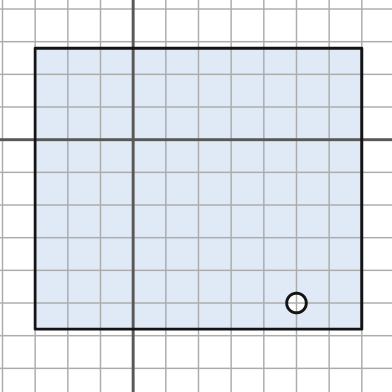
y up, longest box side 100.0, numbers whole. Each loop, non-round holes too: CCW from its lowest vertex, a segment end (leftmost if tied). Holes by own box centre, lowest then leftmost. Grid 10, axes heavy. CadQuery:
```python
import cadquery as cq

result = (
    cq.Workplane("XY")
    .moveTo(-30.0, -58.0)
    .lineTo(70.0, -58.0)
    .lineTo(70.0, 28.0)
    .lineTo(-30.0, 28.0)
    .close()
    .moveTo(50.0, -50.0)
    .circle(3.0)
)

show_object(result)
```